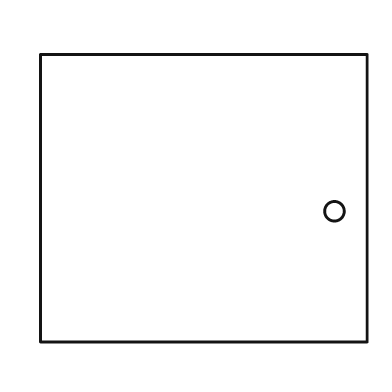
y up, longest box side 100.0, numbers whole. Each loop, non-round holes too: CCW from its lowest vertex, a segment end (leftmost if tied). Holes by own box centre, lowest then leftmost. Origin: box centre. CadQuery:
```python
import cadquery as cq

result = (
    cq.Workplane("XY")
    .moveTo(-50.0, -44.0)
    .lineTo(50.0, -44.0)
    .lineTo(50.0, 44.0)
    .lineTo(-50.0, 44.0)
    .close()
    .moveTo(40.0, -4.0)
    .circle(3.0)
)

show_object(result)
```